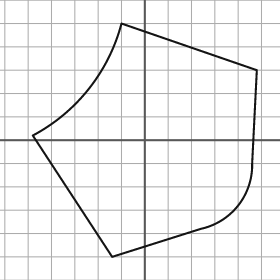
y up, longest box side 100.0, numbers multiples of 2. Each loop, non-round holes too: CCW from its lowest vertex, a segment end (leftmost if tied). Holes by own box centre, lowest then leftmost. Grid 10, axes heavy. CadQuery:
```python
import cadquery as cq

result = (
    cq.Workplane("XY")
    .moveTo(-14.0, -50.0)
    .lineTo(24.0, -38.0)
    .threePointArc((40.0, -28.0), (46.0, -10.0))
    .lineTo(48.0, 30.0)
    .lineTo(-10.0, 50.0)
    .threePointArc((-24.0, 22.0), (-48.0, 2.0))
    .close()
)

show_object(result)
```